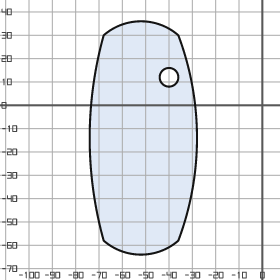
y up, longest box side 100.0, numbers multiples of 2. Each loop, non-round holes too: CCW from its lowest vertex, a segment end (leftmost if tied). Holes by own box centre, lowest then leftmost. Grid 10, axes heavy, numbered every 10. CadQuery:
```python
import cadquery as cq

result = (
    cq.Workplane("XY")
    .moveTo(-68.0, -58.0)
    .threePointArc((-52.0, -64.0), (-36.0, -58.0))
    .threePointArc((-28.0, -14.0), (-36.0, 30.0))
    .threePointArc((-52.0, 36.0), (-68.0, 30.0))
    .threePointArc((-74.0, -14.0), (-68.0, -58.0))
    .close()
    .moveTo(-40.0, 12.0)
    .circle(4.0)
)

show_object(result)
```